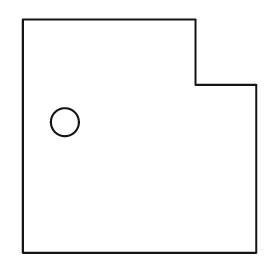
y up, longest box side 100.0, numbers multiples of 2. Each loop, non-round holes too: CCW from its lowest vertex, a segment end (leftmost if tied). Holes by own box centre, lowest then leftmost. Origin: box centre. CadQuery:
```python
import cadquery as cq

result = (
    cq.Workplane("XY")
    .moveTo(-50.0, -50.0)
    .lineTo(50.0, -50.0)
    .lineTo(50.0, 22.0)
    .lineTo(24.0, 22.0)
    .lineTo(24.0, 50.0)
    .lineTo(-50.0, 50.0)
    .close()
    .moveTo(-32.0, 6.0)
    .circle(6.0)
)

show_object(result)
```